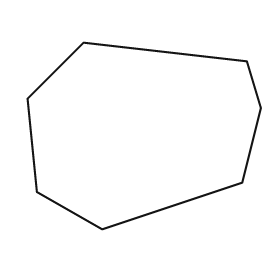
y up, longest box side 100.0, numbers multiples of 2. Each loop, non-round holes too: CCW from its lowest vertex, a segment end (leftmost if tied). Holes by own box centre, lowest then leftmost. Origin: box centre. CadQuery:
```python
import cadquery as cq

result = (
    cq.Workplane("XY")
    .moveTo(-18.0, -40.0)
    .lineTo(42.0, -20.0)
    .lineTo(50.0, 12.0)
    .lineTo(44.0, 32.0)
    .lineTo(-26.0, 40.0)
    .lineTo(-50.0, 16.0)
    .lineTo(-46.0, -24.0)
    .close()
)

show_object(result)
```